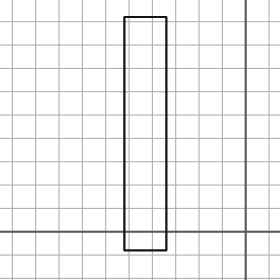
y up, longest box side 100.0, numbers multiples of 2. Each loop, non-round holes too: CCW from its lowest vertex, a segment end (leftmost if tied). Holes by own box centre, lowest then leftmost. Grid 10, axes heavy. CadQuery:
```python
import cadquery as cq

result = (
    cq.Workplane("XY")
    .moveTo(-52.0, -8.0)
    .lineTo(-34.0, -8.0)
    .lineTo(-34.0, 92.0)
    .lineTo(-52.0, 92.0)
    .close()
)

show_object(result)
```